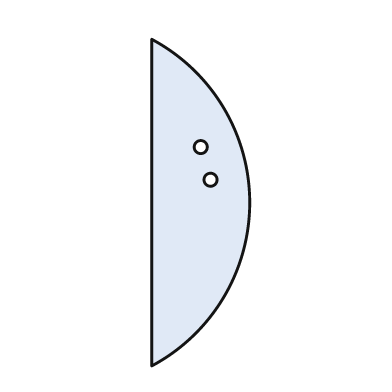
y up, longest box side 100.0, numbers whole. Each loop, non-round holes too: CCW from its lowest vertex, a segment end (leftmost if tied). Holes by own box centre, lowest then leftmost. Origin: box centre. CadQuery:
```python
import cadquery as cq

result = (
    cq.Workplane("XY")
    .moveTo(-15.0, -50.0)
    .threePointArc((15.0, 0.0), (-15.0, 50.0))
    .close()
    .moveTo(3.0, 7.0)
    .circle(2.0)
    .moveTo(0.0, 17.0)
    .circle(2.0)
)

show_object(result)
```